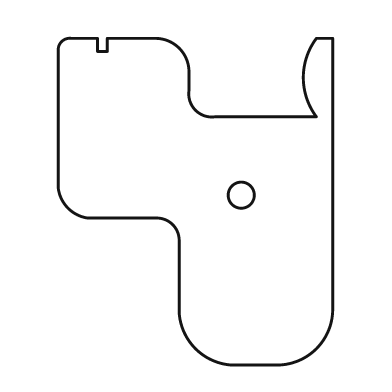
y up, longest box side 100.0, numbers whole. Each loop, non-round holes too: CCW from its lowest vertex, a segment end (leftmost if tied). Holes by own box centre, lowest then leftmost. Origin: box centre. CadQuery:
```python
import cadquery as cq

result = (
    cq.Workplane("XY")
    .moveTo(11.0, -50.0)
    .lineTo(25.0, -50.0)
    .threePointArc((37.0, -45.0), (42.0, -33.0))
    .lineTo(42.0, 50.0)
    .lineTo(37.0, 50.0)
    .threePointArc((33.0, 38.0), (37.0, 26.0))
    .lineTo(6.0, 26.0)
    .threePointArc((0.0, 28.0), (-2.0, 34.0))
    .lineTo(-2.0, 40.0)
    .threePointArc((-5.0, 47.0), (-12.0, 50.0))
    .lineTo(-27.0, 50.0)
    .lineTo(-27.0, 46.0)
    .lineTo(-30.0, 46.0)
    .lineTo(-30.0, 50.0)
    .lineTo(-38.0, 50.0)
    .threePointArc((-41.0, 49.0), (-42.0, 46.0))
    .lineTo(-42.0, 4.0)
    .threePointArc((-39.0, -2.0), (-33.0, -5.0))
    .lineTo(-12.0, -5.0)
    .threePointArc((-7.0, -7.0), (-5.0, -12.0))
    .lineTo(-5.0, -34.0)
    .threePointArc((0.0, -45.0), (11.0, -50.0))
    .close()
    .moveTo(14.0, 2.0)
    .circle(4.0)
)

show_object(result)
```